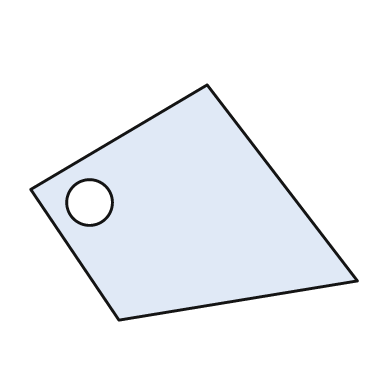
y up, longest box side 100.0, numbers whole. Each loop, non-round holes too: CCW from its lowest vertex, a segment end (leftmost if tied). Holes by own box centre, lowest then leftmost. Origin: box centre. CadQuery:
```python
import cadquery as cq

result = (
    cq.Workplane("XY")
    .moveTo(-23.0, -36.0)
    .lineTo(50.0, -24.0)
    .lineTo(4.0, 36.0)
    .lineTo(-50.0, 4.0)
    .close()
    .moveTo(-32.0, 0.0)
    .circle(7.0)
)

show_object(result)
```